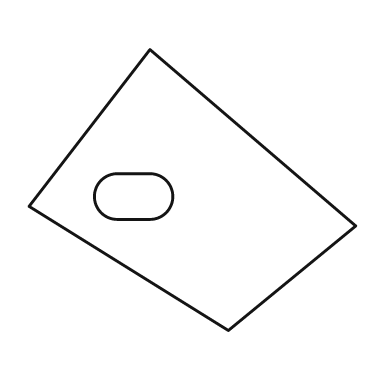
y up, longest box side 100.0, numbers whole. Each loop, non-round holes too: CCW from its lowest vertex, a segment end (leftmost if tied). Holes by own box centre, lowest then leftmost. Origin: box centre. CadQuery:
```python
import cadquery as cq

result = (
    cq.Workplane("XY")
    .moveTo(11.0, -43.0)
    .lineTo(50.0, -11.0)
    .lineTo(-13.0, 43.0)
    .lineTo(-50.0, -5.0)
    .close()
    .moveTo(-23.0, -9.0)
    .lineTo(-13.0, -9.0)
    .threePointArc((-6.0, -2.0), (-13.0, 5.0))
    .lineTo(-23.0, 5.0)
    .threePointArc((-30.0, -2.0), (-23.0, -9.0))
    .close()
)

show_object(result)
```